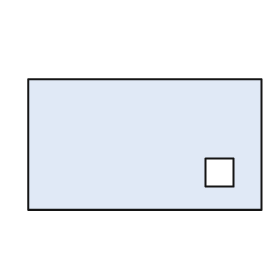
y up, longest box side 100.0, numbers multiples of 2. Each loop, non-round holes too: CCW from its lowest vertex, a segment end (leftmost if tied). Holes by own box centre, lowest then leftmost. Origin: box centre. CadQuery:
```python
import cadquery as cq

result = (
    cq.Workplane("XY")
    .moveTo(-50.0, -28.0)
    .lineTo(50.0, -28.0)
    .lineTo(50.0, 28.0)
    .lineTo(-50.0, 28.0)
    .close()
    .moveTo(26.0, -18.0)
    .lineTo(38.0, -18.0)
    .lineTo(38.0, -6.0)
    .lineTo(26.0, -6.0)
    .close()
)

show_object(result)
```